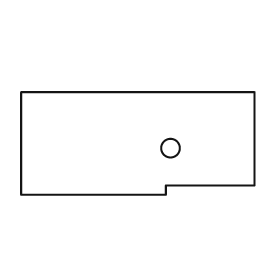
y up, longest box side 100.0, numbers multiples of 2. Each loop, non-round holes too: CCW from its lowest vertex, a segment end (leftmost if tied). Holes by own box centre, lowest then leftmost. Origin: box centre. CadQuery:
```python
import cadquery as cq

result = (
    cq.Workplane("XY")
    .moveTo(-50.0, -22.0)
    .lineTo(12.0, -22.0)
    .lineTo(12.0, -18.0)
    .lineTo(50.0, -18.0)
    .lineTo(50.0, 22.0)
    .lineTo(-50.0, 22.0)
    .close()
    .moveTo(14.0, -2.0)
    .circle(4.0)
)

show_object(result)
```